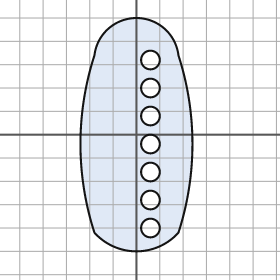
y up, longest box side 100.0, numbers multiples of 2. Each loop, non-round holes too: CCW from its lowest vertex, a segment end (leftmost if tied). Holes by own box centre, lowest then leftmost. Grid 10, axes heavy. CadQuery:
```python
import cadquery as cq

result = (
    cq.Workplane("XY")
    .moveTo(-18.0, -42.0)
    .threePointArc((0.0, -50.0), (18.0, -42.0))
    .threePointArc((24.0, -4.0), (18.0, 34.0))
    .threePointArc((0.0, 50.0), (-18.0, 34.0))
    .threePointArc((-24.0, -4.0), (-18.0, -42.0))
    .close()
    .moveTo(6.0, -40.0)
    .circle(4.0)
    .moveTo(6.0, -28.0)
    .circle(4.0)
    .moveTo(6.0, -16.0)
    .circle(4.0)
    .moveTo(6.0, -4.0)
    .circle(4.0)
    .moveTo(6.0, 8.0)
    .circle(4.0)
    .moveTo(6.0, 20.0)
    .circle(4.0)
    .moveTo(6.0, 32.0)
    .circle(4.0)
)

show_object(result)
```